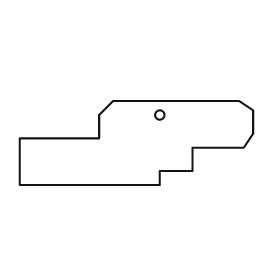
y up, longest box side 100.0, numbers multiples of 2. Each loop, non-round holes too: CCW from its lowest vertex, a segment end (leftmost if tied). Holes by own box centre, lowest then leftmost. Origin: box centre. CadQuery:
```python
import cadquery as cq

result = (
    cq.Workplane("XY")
    .moveTo(-50.0, -18.0)
    .lineTo(10.0, -18.0)
    .lineTo(10.0, -12.0)
    .lineTo(24.0, -12.0)
    .lineTo(24.0, -2.0)
    .lineTo(46.0, -2.0)
    .lineTo(50.0, 4.0)
    .lineTo(50.0, 14.0)
    .lineTo(44.0, 18.0)
    .lineTo(-10.0, 18.0)
    .lineTo(-16.0, 12.0)
    .lineTo(-16.0, 2.0)
    .lineTo(-50.0, 2.0)
    .close()
    .moveTo(10.0, 12.0)
    .circle(2.0)
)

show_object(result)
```